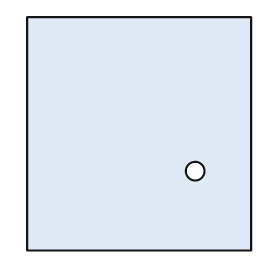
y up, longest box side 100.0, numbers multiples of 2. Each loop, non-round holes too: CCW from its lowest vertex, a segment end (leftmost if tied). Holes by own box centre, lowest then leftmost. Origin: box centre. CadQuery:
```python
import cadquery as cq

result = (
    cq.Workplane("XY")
    .moveTo(-48.0, -50.0)
    .lineTo(48.0, -50.0)
    .lineTo(48.0, 50.0)
    .lineTo(-48.0, 50.0)
    .close()
    .moveTo(24.0, -16.0)
    .circle(4.0)
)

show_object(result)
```